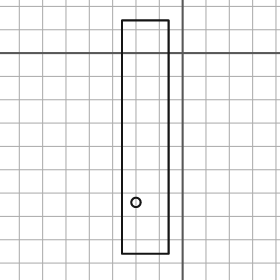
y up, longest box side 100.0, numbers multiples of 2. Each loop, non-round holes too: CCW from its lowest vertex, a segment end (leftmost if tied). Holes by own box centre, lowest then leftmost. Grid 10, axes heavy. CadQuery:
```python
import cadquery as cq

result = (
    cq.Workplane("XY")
    .moveTo(-26.0, -86.0)
    .lineTo(-6.0, -86.0)
    .lineTo(-6.0, 14.0)
    .lineTo(-26.0, 14.0)
    .close()
    .moveTo(-20.0, -64.0)
    .circle(2.0)
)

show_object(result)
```